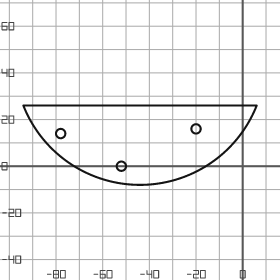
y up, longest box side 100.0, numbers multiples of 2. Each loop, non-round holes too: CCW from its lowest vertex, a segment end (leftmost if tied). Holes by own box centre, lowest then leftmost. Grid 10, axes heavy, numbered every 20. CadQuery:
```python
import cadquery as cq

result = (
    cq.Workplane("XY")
    .moveTo(-94.0, 26.0)
    .threePointArc((-44.0, -8.0), (6.0, 26.0))
    .close()
    .moveTo(-52.0, 0.0)
    .circle(2.0)
    .moveTo(-78.0, 14.0)
    .circle(2.0)
    .moveTo(-20.0, 16.0)
    .circle(2.0)
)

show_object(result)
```